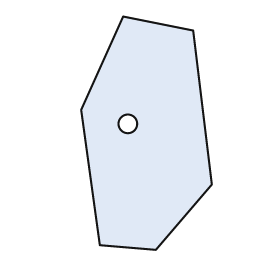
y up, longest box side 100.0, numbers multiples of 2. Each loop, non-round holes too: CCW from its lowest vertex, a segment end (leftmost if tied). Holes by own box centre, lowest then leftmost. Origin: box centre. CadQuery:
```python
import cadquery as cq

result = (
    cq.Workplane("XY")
    .moveTo(4.0, -50.0)
    .lineTo(28.0, -22.0)
    .lineTo(20.0, 44.0)
    .lineTo(-10.0, 50.0)
    .lineTo(-28.0, 10.0)
    .lineTo(-20.0, -48.0)
    .close()
    .moveTo(-8.0, 4.0)
    .circle(4.0)
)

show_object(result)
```